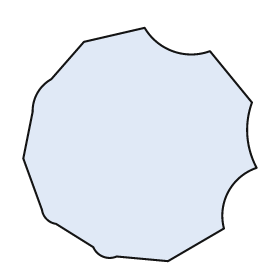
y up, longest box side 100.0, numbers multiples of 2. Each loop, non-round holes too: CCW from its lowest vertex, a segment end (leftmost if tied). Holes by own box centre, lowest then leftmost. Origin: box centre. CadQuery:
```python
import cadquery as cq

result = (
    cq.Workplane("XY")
    .moveTo(12.0, -50.0)
    .lineTo(36.0, -36.0)
    .threePointArc((38.0, -20.0), (50.0, -10.0))
    .threePointArc((46.0, 4.0), (48.0, 18.0))
    .lineTo(30.0, 40.0)
    .threePointArc((14.0, 40.0), (2.0, 50.0))
    .lineTo(-24.0, 44.0)
    .lineTo(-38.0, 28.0)
    .threePointArc((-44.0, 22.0), (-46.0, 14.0))
    .lineTo(-50.0, -6.0)
    .lineTo(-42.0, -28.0)
    .threePointArc((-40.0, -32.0), (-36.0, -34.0))
    .lineTo(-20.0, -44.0)
    .threePointArc((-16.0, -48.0), (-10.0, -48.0))
    .close()
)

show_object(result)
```